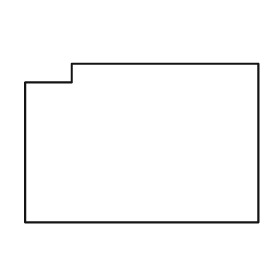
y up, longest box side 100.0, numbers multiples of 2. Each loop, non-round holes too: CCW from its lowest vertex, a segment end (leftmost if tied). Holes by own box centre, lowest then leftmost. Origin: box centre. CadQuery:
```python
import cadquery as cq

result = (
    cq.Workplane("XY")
    .moveTo(-50.0, -34.0)
    .lineTo(50.0, -34.0)
    .lineTo(50.0, 34.0)
    .lineTo(-30.0, 34.0)
    .lineTo(-30.0, 26.0)
    .lineTo(-50.0, 26.0)
    .close()
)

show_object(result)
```